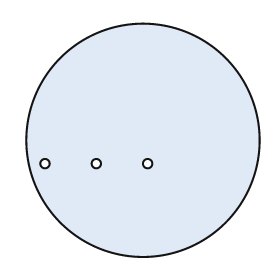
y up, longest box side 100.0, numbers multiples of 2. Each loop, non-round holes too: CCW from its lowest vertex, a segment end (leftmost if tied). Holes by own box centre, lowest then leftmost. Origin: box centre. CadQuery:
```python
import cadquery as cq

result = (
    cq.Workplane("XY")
    .moveTo(0.0, 0.0)
    .circle(50.0)
    .moveTo(-42.0, -10.0)
    .circle(2.0)
    .moveTo(-20.0, -10.0)
    .circle(2.0)
    .moveTo(2.0, -10.0)
    .circle(2.0)
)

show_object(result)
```